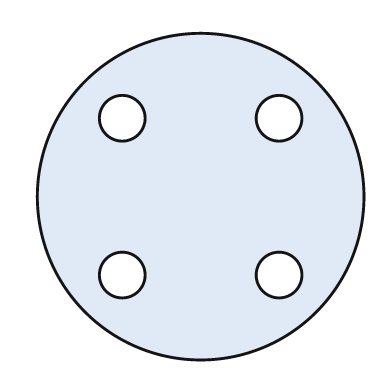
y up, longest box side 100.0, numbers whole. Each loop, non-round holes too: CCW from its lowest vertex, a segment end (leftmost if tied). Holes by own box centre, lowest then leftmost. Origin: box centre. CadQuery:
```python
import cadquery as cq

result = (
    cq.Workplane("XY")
    .moveTo(0.0, 0.0)
    .circle(50.0)
    .moveTo(-24.0, -24.0)
    .circle(7.0)
    .moveTo(24.0, -24.0)
    .circle(7.0)
    .moveTo(-24.0, 24.0)
    .circle(7.0)
    .moveTo(24.0, 24.0)
    .circle(7.0)
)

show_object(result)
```